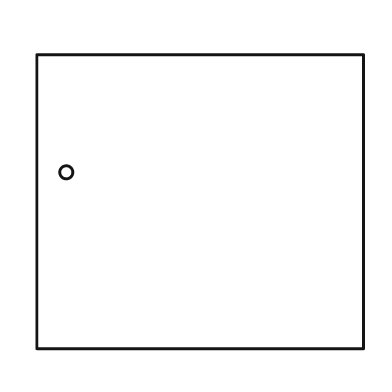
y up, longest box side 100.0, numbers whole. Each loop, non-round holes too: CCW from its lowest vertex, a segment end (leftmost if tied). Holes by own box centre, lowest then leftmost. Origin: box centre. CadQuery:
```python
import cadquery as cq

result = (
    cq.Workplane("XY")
    .moveTo(-50.0, -45.0)
    .lineTo(50.0, -45.0)
    .lineTo(50.0, 45.0)
    .lineTo(-50.0, 45.0)
    .close()
    .moveTo(-41.0, 9.0)
    .circle(2.0)
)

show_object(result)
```